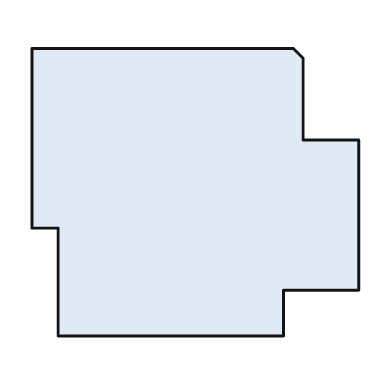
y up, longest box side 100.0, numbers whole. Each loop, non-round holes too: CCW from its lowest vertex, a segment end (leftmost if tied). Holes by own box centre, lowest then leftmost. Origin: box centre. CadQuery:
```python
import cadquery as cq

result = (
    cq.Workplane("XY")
    .moveTo(-42.0, -44.0)
    .lineTo(27.0, -44.0)
    .lineTo(27.0, -30.0)
    .lineTo(50.0, -30.0)
    .lineTo(50.0, 16.0)
    .lineTo(33.0, 16.0)
    .lineTo(33.0, 41.0)
    .lineTo(30.0, 44.0)
    .lineTo(-50.0, 44.0)
    .lineTo(-50.0, -11.0)
    .lineTo(-42.0, -11.0)
    .close()
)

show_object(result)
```